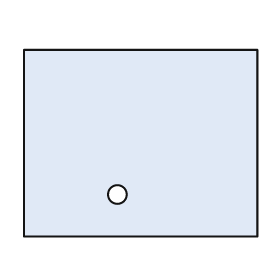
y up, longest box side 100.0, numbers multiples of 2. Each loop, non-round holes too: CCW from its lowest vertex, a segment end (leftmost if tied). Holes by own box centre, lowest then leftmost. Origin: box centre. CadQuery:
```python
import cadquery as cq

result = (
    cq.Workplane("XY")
    .moveTo(-50.0, -40.0)
    .lineTo(50.0, -40.0)
    .lineTo(50.0, 40.0)
    .lineTo(-50.0, 40.0)
    .close()
    .moveTo(-10.0, -22.0)
    .circle(4.0)
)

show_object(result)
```